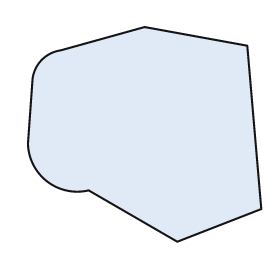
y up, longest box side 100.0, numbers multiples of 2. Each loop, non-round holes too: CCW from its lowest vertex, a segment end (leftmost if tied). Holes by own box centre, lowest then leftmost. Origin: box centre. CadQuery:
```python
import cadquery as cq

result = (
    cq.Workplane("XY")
    .moveTo(14.0, -46.0)
    .lineTo(50.0, -32.0)
    .lineTo(44.0, 38.0)
    .lineTo(0.0, 46.0)
    .lineTo(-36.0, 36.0)
    .threePointArc((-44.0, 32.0), (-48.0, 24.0))
    .lineTo(-50.0, -4.0)
    .threePointArc((-42.0, -20.0), (-24.0, -24.0))
    .close()
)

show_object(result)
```